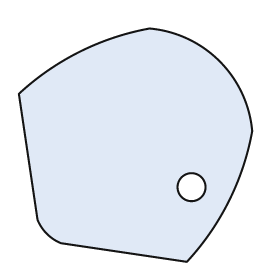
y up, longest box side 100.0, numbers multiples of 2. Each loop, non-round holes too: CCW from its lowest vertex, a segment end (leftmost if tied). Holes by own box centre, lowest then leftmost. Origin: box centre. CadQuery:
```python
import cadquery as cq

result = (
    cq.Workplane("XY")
    .moveTo(22.0, -50.0)
    .threePointArc((40.0, -24.0), (50.0, 6.0))
    .threePointArc((36.0, 36.0), (6.0, 50.0))
    .threePointArc((-24.0, 40.0), (-50.0, 22.0))
    .lineTo(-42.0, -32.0)
    .threePointArc((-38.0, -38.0), (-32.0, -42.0))
    .close()
    .moveTo(24.0, -18.0)
    .circle(6.0)
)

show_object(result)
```